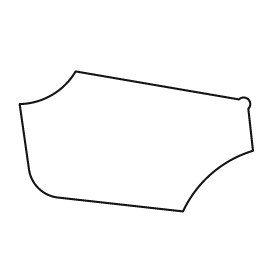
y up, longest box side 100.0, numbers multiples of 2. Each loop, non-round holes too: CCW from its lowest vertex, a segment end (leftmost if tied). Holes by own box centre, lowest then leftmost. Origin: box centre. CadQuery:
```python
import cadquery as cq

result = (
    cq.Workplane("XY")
    .moveTo(20.0, -30.0)
    .threePointArc((32.0, -14.0), (50.0, -4.0))
    .lineTo(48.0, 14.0)
    .threePointArc((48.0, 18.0), (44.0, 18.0))
    .lineTo(-26.0, 30.0)
    .threePointArc((-36.0, 20.0), (-50.0, 16.0))
    .lineTo(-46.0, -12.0)
    .threePointArc((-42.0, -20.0), (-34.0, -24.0))
    .close()
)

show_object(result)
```